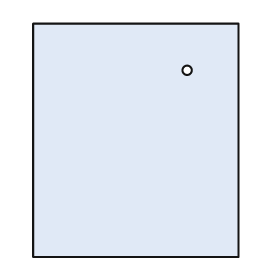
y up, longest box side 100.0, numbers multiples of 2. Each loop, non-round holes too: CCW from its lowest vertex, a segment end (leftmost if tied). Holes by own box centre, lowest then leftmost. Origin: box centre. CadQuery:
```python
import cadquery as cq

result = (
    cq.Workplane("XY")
    .moveTo(-44.0, -50.0)
    .lineTo(44.0, -50.0)
    .lineTo(44.0, 50.0)
    .lineTo(-44.0, 50.0)
    .close()
    .moveTo(22.0, 30.0)
    .circle(2.0)
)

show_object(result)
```